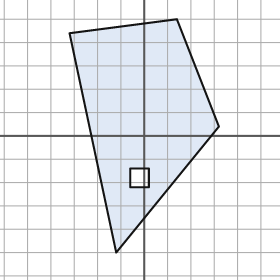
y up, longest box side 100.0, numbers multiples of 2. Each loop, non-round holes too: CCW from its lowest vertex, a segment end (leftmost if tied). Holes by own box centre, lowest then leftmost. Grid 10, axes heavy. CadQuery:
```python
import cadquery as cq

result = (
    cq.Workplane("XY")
    .moveTo(-12.0, -50.0)
    .lineTo(32.0, 4.0)
    .lineTo(14.0, 50.0)
    .lineTo(-32.0, 44.0)
    .close()
    .moveTo(-6.0, -22.0)
    .lineTo(2.0, -22.0)
    .lineTo(2.0, -14.0)
    .lineTo(-6.0, -14.0)
    .close()
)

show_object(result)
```